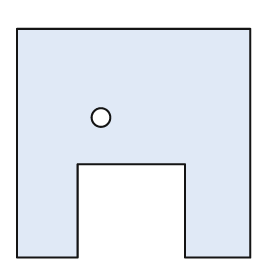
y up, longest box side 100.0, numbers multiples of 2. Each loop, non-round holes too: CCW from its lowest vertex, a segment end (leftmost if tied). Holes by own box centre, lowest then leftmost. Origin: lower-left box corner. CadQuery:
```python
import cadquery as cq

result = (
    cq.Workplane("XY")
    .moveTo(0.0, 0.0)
    .lineTo(26.0, 0.0)
    .lineTo(26.0, 40.0)
    .lineTo(72.0, 40.0)
    .lineTo(72.0, 0.0)
    .lineTo(100.0, 0.0)
    .lineTo(100.0, 98.0)
    .lineTo(0.0, 98.0)
    .close()
    .moveTo(36.0, 60.0)
    .circle(4.0)
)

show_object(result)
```